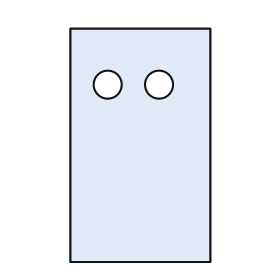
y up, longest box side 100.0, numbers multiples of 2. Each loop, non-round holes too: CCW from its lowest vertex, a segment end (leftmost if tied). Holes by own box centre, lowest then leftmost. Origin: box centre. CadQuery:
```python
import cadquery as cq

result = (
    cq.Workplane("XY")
    .moveTo(-30.0, -50.0)
    .lineTo(30.0, -50.0)
    .lineTo(30.0, 50.0)
    .lineTo(-30.0, 50.0)
    .close()
    .moveTo(-14.0, 26.0)
    .circle(6.0)
    .moveTo(8.0, 26.0)
    .circle(6.0)
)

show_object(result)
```